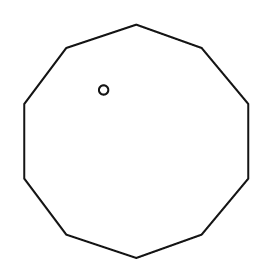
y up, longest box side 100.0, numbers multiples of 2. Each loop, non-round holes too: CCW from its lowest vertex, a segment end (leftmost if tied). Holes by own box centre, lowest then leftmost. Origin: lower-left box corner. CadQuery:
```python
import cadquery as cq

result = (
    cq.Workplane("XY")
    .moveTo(48.0, 0.0)
    .lineTo(76.0, 10.0)
    .lineTo(96.0, 34.0)
    .lineTo(96.0, 66.0)
    .lineTo(76.0, 90.0)
    .lineTo(48.0, 100.0)
    .lineTo(18.0, 90.0)
    .lineTo(0.0, 66.0)
    .lineTo(0.0, 34.0)
    .lineTo(18.0, 10.0)
    .close()
    .moveTo(34.0, 72.0)
    .circle(2.0)
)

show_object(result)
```